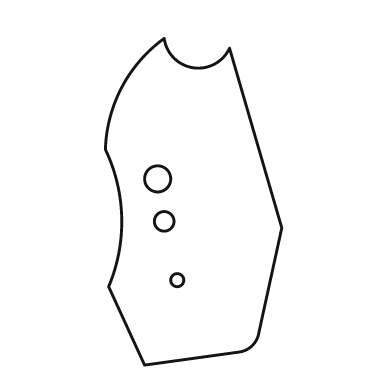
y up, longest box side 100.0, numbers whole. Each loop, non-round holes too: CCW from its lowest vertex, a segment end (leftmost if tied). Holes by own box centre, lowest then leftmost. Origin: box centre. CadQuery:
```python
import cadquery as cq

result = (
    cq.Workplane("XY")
    .moveTo(-15.0, -50.0)
    .lineTo(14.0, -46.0)
    .threePointArc((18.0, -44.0), (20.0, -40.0))
    .lineTo(27.0, -8.0)
    .lineTo(11.0, 47.0)
    .threePointArc((0.0, 41.0), (-9.0, 50.0))
    .threePointArc((-22.0, 35.0), (-27.0, 16.0))
    .threePointArc((-22.0, -5.0), (-26.0, -26.0))
    .close()
    .moveTo(-5.0, -24.0)
    .circle(2.0)
    .moveTo(-9.0, -6.0)
    .circle(3.0)
    .moveTo(-11.0, 7.0)
    .circle(4.0)
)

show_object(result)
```